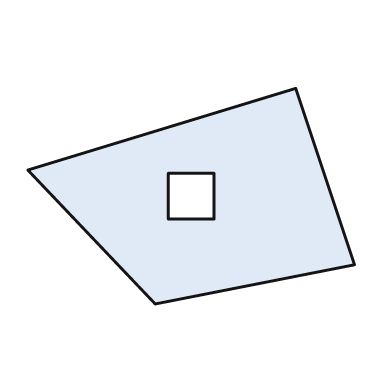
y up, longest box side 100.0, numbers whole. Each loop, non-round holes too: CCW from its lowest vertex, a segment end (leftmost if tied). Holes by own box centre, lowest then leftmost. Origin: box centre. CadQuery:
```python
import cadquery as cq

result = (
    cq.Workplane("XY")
    .moveTo(-11.0, -33.0)
    .lineTo(50.0, -21.0)
    .lineTo(32.0, 33.0)
    .lineTo(-50.0, 8.0)
    .close()
    .moveTo(-7.0, -7.0)
    .lineTo(7.0, -7.0)
    .lineTo(7.0, 7.0)
    .lineTo(-7.0, 7.0)
    .close()
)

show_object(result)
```